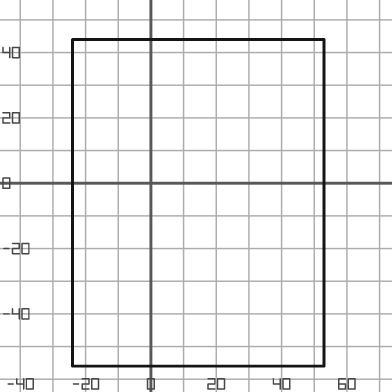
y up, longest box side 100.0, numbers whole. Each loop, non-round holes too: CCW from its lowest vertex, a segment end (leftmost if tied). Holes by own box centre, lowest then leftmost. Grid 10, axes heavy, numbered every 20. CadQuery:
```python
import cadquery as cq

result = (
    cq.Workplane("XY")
    .moveTo(-24.0, -56.0)
    .lineTo(53.0, -56.0)
    .lineTo(53.0, 44.0)
    .lineTo(-24.0, 44.0)
    .close()
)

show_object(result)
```